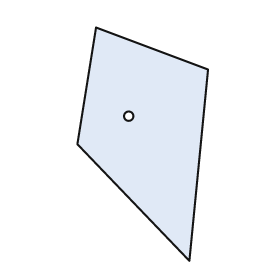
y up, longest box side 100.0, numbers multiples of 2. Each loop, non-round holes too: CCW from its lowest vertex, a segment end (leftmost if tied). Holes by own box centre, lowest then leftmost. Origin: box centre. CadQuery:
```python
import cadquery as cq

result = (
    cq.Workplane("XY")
    .moveTo(20.0, -50.0)
    .lineTo(28.0, 32.0)
    .lineTo(-20.0, 50.0)
    .lineTo(-28.0, 0.0)
    .close()
    .moveTo(-6.0, 12.0)
    .circle(2.0)
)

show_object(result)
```